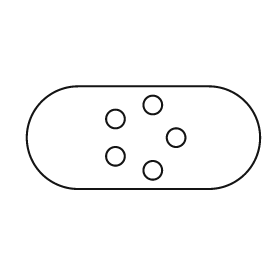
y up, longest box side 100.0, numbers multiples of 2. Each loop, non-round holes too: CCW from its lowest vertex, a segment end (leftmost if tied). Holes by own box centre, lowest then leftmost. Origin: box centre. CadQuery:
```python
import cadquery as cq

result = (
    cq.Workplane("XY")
    .moveTo(-28.0, -22.0)
    .lineTo(28.0, -22.0)
    .threePointArc((50.0, 0.0), (28.0, 22.0))
    .lineTo(-28.0, 22.0)
    .threePointArc((-50.0, 0.0), (-28.0, -22.0))
    .close()
    .moveTo(4.0, -14.0)
    .circle(4.0)
    .moveTo(-12.0, -8.0)
    .circle(4.0)
    .moveTo(14.0, 0.0)
    .circle(4.0)
    .moveTo(-12.0, 8.0)
    .circle(4.0)
    .moveTo(4.0, 14.0)
    .circle(4.0)
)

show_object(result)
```